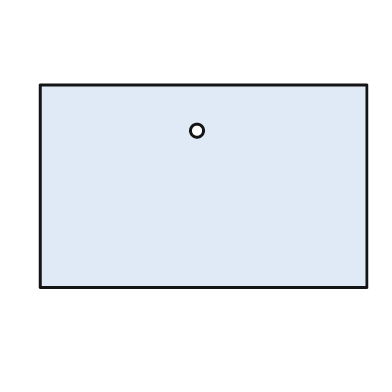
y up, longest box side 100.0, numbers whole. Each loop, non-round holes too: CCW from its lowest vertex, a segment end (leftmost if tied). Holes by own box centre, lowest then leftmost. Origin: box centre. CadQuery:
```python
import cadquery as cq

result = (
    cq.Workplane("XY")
    .moveTo(-50.0, -31.0)
    .lineTo(50.0, -31.0)
    .lineTo(50.0, 31.0)
    .lineTo(-50.0, 31.0)
    .close()
    .moveTo(-2.0, 17.0)
    .circle(2.0)
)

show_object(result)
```